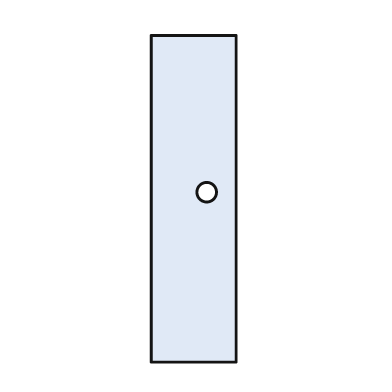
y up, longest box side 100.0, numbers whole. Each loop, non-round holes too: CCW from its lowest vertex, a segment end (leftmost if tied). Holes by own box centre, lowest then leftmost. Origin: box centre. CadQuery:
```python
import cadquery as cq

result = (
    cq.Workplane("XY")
    .moveTo(-13.0, -50.0)
    .lineTo(13.0, -50.0)
    .lineTo(13.0, 50.0)
    .lineTo(-13.0, 50.0)
    .close()
    .moveTo(4.0, 2.0)
    .circle(3.0)
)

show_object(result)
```